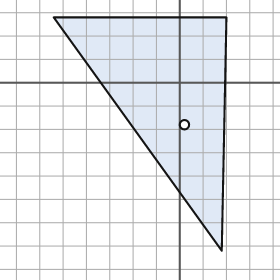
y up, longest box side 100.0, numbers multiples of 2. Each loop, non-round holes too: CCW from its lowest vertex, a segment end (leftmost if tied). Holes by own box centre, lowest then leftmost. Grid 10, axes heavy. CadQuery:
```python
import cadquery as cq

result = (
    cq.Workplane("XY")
    .moveTo(18.0, -72.0)
    .lineTo(20.0, 28.0)
    .lineTo(-54.0, 28.0)
    .close()
    .moveTo(2.0, -18.0)
    .circle(2.0)
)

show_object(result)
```